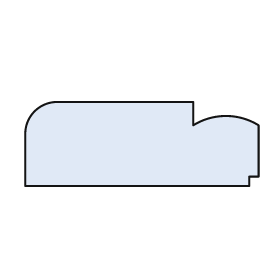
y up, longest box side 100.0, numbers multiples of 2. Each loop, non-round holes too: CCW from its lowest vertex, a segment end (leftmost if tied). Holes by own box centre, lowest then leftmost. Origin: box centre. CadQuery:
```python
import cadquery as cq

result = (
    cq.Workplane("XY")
    .moveTo(-50.0, -18.0)
    .lineTo(46.0, -18.0)
    .lineTo(46.0, -14.0)
    .lineTo(50.0, -14.0)
    .lineTo(50.0, 8.0)
    .threePointArc((36.0, 12.0), (22.0, 8.0))
    .lineTo(22.0, 18.0)
    .lineTo(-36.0, 18.0)
    .threePointArc((-46.0, 14.0), (-50.0, 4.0))
    .close()
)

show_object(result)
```